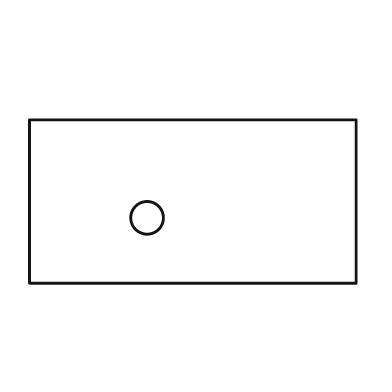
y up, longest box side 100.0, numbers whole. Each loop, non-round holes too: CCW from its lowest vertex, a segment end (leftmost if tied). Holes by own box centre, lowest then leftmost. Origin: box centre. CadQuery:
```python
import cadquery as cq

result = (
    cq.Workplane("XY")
    .moveTo(-50.0, -25.0)
    .lineTo(50.0, -25.0)
    .lineTo(50.0, 25.0)
    .lineTo(-50.0, 25.0)
    .close()
    .moveTo(-14.0, -5.0)
    .circle(5.0)
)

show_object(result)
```